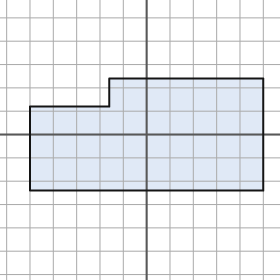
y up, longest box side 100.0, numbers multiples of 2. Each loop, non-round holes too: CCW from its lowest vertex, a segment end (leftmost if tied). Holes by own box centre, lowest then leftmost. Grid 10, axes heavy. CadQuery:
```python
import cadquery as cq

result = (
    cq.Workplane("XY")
    .moveTo(-50.0, -24.0)
    .lineTo(50.0, -24.0)
    .lineTo(50.0, 24.0)
    .lineTo(-16.0, 24.0)
    .lineTo(-16.0, 12.0)
    .lineTo(-50.0, 12.0)
    .close()
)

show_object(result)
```